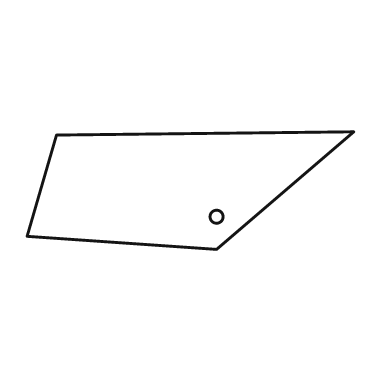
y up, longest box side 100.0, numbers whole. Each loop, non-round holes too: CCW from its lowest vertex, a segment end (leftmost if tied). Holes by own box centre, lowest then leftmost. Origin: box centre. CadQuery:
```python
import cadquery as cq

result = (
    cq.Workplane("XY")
    .moveTo(8.0, -18.0)
    .lineTo(50.0, 18.0)
    .lineTo(-41.0, 17.0)
    .lineTo(-50.0, -14.0)
    .close()
    .moveTo(8.0, -8.0)
    .circle(2.0)
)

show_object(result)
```